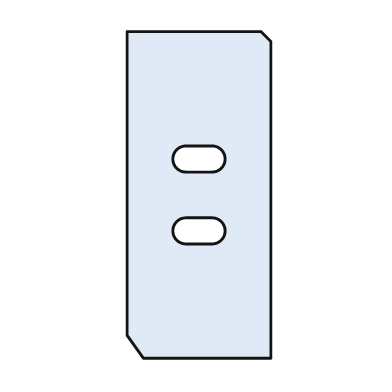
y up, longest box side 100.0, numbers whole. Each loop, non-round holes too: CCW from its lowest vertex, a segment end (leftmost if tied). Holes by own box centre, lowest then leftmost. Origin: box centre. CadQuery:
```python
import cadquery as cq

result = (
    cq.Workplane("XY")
    .moveTo(-17.0, -50.0)
    .lineTo(22.0, -50.0)
    .lineTo(22.0, 47.0)
    .lineTo(19.0, 50.0)
    .lineTo(-22.0, 50.0)
    .lineTo(-22.0, -43.0)
    .close()
    .moveTo(-4.0, -15.0)
    .lineTo(4.0, -15.0)
    .threePointArc((8.0, -11.0), (4.0, -7.0))
    .lineTo(-4.0, -7.0)
    .threePointArc((-8.0, -11.0), (-4.0, -15.0))
    .close()
    .moveTo(-4.0, 7.0)
    .lineTo(4.0, 7.0)
    .threePointArc((8.0, 11.0), (4.0, 15.0))
    .lineTo(-4.0, 15.0)
    .threePointArc((-8.0, 11.0), (-4.0, 7.0))
    .close()
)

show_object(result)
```